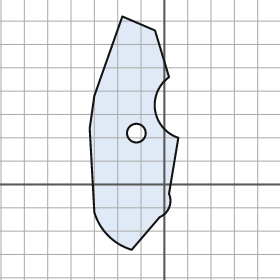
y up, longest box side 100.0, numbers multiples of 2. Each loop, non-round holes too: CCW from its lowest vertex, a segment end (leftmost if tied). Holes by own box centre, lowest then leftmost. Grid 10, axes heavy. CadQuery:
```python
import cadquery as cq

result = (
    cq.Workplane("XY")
    .moveTo(-14.0, -28.0)
    .lineTo(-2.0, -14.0)
    .threePointArc((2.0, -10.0), (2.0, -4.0))
    .lineTo(6.0, 20.0)
    .threePointArc((-4.0, 32.0), (2.0, 46.0))
    .lineTo(-4.0, 66.0)
    .lineTo(-18.0, 72.0)
    .lineTo(-30.0, 38.0)
    .lineTo(-32.0, 24.0)
    .lineTo(-30.0, -12.0)
    .threePointArc((-24.0, -22.0), (-14.0, -28.0))
    .close()
    .moveTo(-12.0, 22.0)
    .circle(4.0)
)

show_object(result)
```